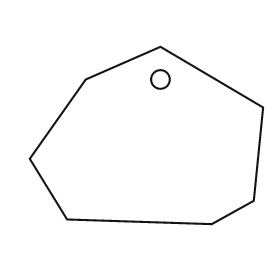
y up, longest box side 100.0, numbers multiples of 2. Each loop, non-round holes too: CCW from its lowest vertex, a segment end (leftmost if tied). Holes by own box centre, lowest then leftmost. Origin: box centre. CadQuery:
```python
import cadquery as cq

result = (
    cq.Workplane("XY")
    .moveTo(28.0, -38.0)
    .lineTo(46.0, -28.0)
    .lineTo(50.0, 12.0)
    .lineTo(6.0, 38.0)
    .lineTo(-26.0, 24.0)
    .lineTo(-50.0, -10.0)
    .lineTo(-34.0, -36.0)
    .close()
    .moveTo(6.0, 24.0)
    .circle(4.0)
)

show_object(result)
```